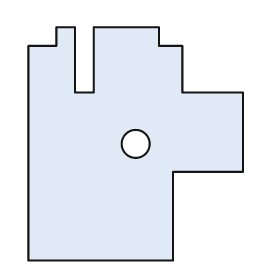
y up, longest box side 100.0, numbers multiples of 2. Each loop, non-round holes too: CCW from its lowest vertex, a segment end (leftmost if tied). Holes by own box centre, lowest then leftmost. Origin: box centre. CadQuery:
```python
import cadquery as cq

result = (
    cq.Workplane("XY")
    .moveTo(-46.0, -50.0)
    .lineTo(16.0, -50.0)
    .lineTo(16.0, -12.0)
    .lineTo(46.0, -12.0)
    .lineTo(46.0, 22.0)
    .lineTo(20.0, 22.0)
    .lineTo(20.0, 42.0)
    .lineTo(10.0, 42.0)
    .lineTo(10.0, 50.0)
    .lineTo(-18.0, 50.0)
    .lineTo(-18.0, 22.0)
    .lineTo(-26.0, 22.0)
    .lineTo(-26.0, 50.0)
    .lineTo(-34.0, 50.0)
    .lineTo(-34.0, 42.0)
    .lineTo(-46.0, 42.0)
    .close()
    .moveTo(0.0, 0.0)
    .circle(6.0)
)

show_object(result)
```